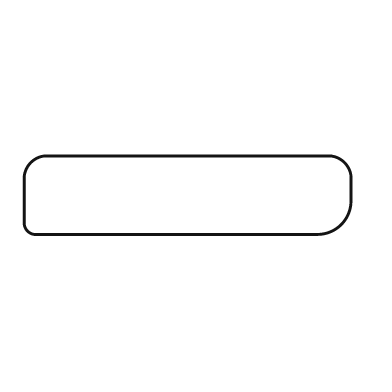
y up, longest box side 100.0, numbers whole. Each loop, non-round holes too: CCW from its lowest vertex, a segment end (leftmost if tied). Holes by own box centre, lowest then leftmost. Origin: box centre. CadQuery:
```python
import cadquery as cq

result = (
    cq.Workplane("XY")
    .moveTo(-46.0, -12.0)
    .lineTo(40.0, -12.0)
    .threePointArc((47.0, -9.0), (50.0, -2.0))
    .lineTo(50.0, 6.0)
    .threePointArc((48.0, 10.0), (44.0, 12.0))
    .lineTo(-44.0, 12.0)
    .threePointArc((-48.0, 10.0), (-50.0, 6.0))
    .lineTo(-50.0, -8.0)
    .threePointArc((-49.0, -11.0), (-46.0, -12.0))
    .close()
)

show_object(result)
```